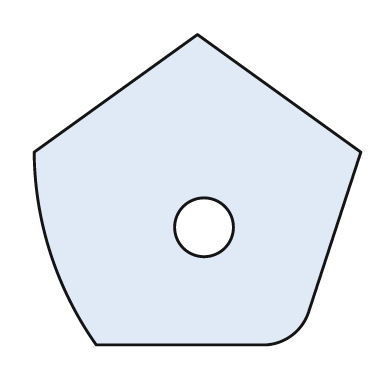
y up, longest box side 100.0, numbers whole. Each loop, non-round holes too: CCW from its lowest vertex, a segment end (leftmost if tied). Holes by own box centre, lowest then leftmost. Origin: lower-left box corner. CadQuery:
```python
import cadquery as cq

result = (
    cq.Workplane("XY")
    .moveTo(19.0, 0.0)
    .lineTo(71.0, 0.0)
    .threePointArc((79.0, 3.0), (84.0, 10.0))
    .lineTo(100.0, 59.0)
    .lineTo(50.0, 95.0)
    .lineTo(0.0, 59.0)
    .threePointArc((5.0, 28.0), (19.0, 0.0))
    .close()
    .moveTo(52.0, 36.0)
    .circle(9.0)
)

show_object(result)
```